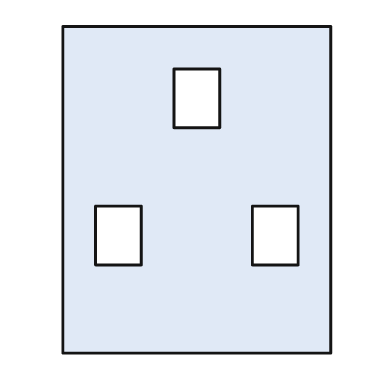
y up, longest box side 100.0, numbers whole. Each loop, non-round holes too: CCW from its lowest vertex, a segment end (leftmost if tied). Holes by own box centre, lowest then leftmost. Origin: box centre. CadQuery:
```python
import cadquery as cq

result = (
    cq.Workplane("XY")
    .moveTo(-41.0, -50.0)
    .lineTo(41.0, -50.0)
    .lineTo(41.0, 50.0)
    .lineTo(-41.0, 50.0)
    .close()
    .moveTo(-31.0, -23.0)
    .lineTo(-17.0, -23.0)
    .lineTo(-17.0, -5.0)
    .lineTo(-31.0, -5.0)
    .close()
    .moveTo(17.0, -23.0)
    .lineTo(31.0, -23.0)
    .lineTo(31.0, -5.0)
    .lineTo(17.0, -5.0)
    .close()
    .moveTo(-7.0, 19.0)
    .lineTo(7.0, 19.0)
    .lineTo(7.0, 37.0)
    .lineTo(-7.0, 37.0)
    .close()
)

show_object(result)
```